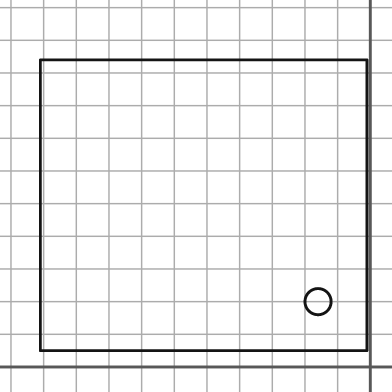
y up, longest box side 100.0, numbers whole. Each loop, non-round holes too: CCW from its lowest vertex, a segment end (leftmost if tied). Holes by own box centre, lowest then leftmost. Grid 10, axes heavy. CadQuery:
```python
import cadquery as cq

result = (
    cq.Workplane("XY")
    .moveTo(-101.0, 5.0)
    .lineTo(-1.0, 5.0)
    .lineTo(-1.0, 94.0)
    .lineTo(-101.0, 94.0)
    .close()
    .moveTo(-16.0, 20.0)
    .circle(4.0)
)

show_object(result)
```